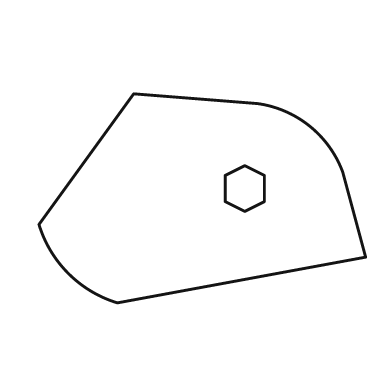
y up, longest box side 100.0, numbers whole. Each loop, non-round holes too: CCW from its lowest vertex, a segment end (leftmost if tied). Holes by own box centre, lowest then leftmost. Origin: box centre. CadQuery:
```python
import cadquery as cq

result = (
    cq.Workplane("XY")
    .moveTo(-26.0, -32.0)
    .lineTo(50.0, -18.0)
    .lineTo(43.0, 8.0)
    .threePointArc((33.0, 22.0), (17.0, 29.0))
    .lineTo(-21.0, 32.0)
    .lineTo(-50.0, -8.0)
    .threePointArc((-41.0, -23.0), (-26.0, -32.0))
    .close()
    .moveTo(13.0, -4.0)
    .lineTo(19.0, -1.0)
    .lineTo(19.0, 7.0)
    .lineTo(13.0, 10.0)
    .lineTo(7.0, 7.0)
    .lineTo(7.0, -1.0)
    .close()
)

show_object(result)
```